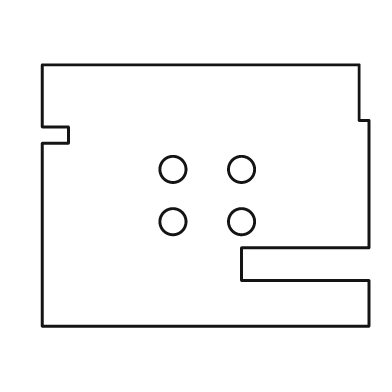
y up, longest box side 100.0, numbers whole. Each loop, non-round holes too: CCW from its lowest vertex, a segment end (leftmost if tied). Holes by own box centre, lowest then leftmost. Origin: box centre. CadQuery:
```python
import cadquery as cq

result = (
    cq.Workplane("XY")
    .moveTo(-50.0, -40.0)
    .lineTo(50.0, -40.0)
    .lineTo(50.0, -26.0)
    .lineTo(11.0, -26.0)
    .lineTo(11.0, -16.0)
    .lineTo(50.0, -16.0)
    .lineTo(50.0, 23.0)
    .lineTo(47.0, 23.0)
    .lineTo(47.0, 40.0)
    .lineTo(-50.0, 40.0)
    .lineTo(-50.0, 21.0)
    .lineTo(-42.0, 21.0)
    .lineTo(-42.0, 16.0)
    .lineTo(-50.0, 16.0)
    .close()
    .moveTo(-10.0, -8.0)
    .circle(4.0)
    .moveTo(11.0, -8.0)
    .circle(4.0)
    .moveTo(-10.0, 8.0)
    .circle(4.0)
    .moveTo(11.0, 8.0)
    .circle(4.0)
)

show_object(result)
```